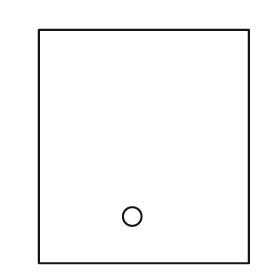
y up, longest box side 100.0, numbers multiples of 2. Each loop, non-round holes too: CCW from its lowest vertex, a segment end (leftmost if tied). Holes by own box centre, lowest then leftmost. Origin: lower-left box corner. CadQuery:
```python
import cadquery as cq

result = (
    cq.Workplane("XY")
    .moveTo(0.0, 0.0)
    .lineTo(90.0, 0.0)
    .lineTo(90.0, 100.0)
    .lineTo(0.0, 100.0)
    .close()
    .moveTo(40.0, 20.0)
    .circle(4.0)
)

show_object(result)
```